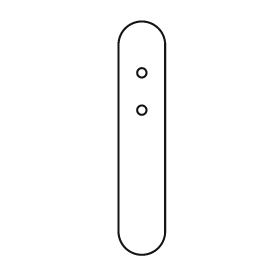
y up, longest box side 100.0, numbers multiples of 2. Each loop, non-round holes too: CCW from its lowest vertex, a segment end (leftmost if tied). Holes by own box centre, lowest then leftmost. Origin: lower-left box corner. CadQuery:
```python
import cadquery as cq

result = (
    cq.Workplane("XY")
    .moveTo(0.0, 10.0)
    .threePointArc((10.0, 0.0), (20.0, 10.0))
    .lineTo(20.0, 90.0)
    .threePointArc((10.0, 100.0), (0.0, 90.0))
    .close()
    .moveTo(10.0, 62.0)
    .circle(2.0)
    .moveTo(10.0, 78.0)
    .circle(2.0)
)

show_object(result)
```